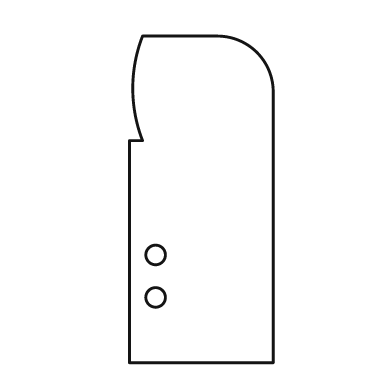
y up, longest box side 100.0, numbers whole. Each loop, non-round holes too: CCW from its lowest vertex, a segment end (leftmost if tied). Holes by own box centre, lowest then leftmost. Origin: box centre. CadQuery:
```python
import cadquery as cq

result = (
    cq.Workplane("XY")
    .moveTo(-22.0, -50.0)
    .lineTo(22.0, -50.0)
    .lineTo(22.0, 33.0)
    .threePointArc((17.0, 45.0), (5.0, 50.0))
    .lineTo(-18.0, 50.0)
    .threePointArc((-21.0, 34.0), (-18.0, 18.0))
    .lineTo(-22.0, 18.0)
    .close()
    .moveTo(-14.0, -30.0)
    .circle(3.0)
    .moveTo(-14.0, -17.0)
    .circle(3.0)
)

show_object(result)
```